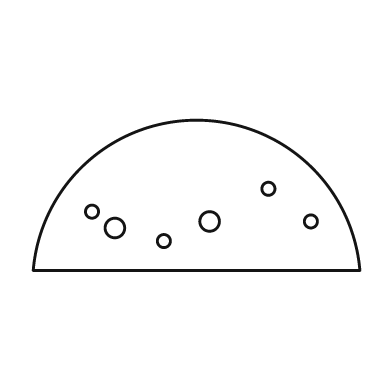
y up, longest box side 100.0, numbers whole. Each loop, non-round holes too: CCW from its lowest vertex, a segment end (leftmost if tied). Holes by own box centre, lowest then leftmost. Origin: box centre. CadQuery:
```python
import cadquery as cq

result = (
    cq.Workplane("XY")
    .moveTo(-50.0, -23.0)
    .lineTo(50.0, -23.0)
    .threePointArc((0.0, 23.0), (-50.0, -23.0))
    .close()
    .moveTo(-10.0, -14.0)
    .circle(2.0)
    .moveTo(-25.0, -10.0)
    .circle(3.0)
    .moveTo(4.0, -8.0)
    .circle(3.0)
    .moveTo(35.0, -8.0)
    .circle(2.0)
    .moveTo(-32.0, -5.0)
    .circle(2.0)
    .moveTo(22.0, 2.0)
    .circle(2.0)
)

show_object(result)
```